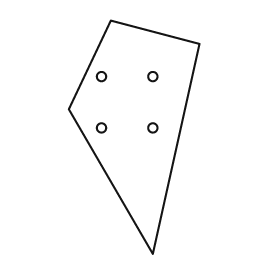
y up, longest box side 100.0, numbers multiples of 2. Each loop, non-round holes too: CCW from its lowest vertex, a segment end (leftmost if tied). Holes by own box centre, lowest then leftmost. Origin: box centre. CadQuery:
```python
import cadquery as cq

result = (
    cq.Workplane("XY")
    .moveTo(8.0, -50.0)
    .lineTo(28.0, 40.0)
    .lineTo(-10.0, 50.0)
    .lineTo(-28.0, 12.0)
    .close()
    .moveTo(-14.0, 4.0)
    .circle(2.0)
    .moveTo(8.0, 4.0)
    .circle(2.0)
    .moveTo(-14.0, 26.0)
    .circle(2.0)
    .moveTo(8.0, 26.0)
    .circle(2.0)
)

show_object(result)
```